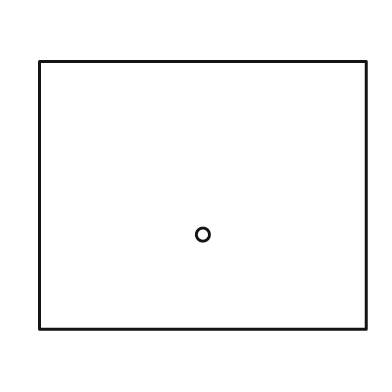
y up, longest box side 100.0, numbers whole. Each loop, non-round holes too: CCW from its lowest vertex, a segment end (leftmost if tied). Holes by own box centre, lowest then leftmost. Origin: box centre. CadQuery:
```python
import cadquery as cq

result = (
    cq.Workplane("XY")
    .moveTo(-50.0, -41.0)
    .lineTo(50.0, -41.0)
    .lineTo(50.0, 41.0)
    .lineTo(-50.0, 41.0)
    .close()
    .moveTo(0.0, -12.0)
    .circle(2.0)
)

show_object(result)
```